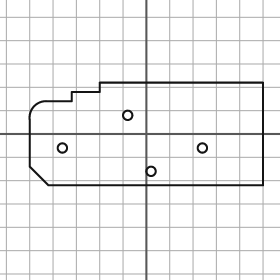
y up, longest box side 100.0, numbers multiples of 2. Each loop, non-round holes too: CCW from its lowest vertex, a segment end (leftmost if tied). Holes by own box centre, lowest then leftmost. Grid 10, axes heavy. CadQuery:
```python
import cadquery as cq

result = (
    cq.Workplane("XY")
    .moveTo(-42.0, -22.0)
    .lineTo(50.0, -22.0)
    .lineTo(50.0, 22.0)
    .lineTo(-20.0, 22.0)
    .lineTo(-20.0, 18.0)
    .lineTo(-32.0, 18.0)
    .lineTo(-32.0, 14.0)
    .lineTo(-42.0, 14.0)
    .threePointArc((-48.0, 12.0), (-50.0, 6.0))
    .lineTo(-50.0, -14.0)
    .close()
    .moveTo(2.0, -16.0)
    .circle(2.0)
    .moveTo(-36.0, -6.0)
    .circle(2.0)
    .moveTo(24.0, -6.0)
    .circle(2.0)
    .moveTo(-8.0, 8.0)
    .circle(2.0)
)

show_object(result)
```